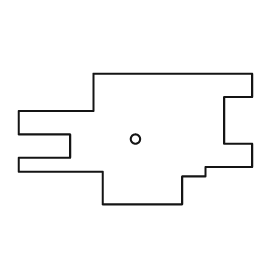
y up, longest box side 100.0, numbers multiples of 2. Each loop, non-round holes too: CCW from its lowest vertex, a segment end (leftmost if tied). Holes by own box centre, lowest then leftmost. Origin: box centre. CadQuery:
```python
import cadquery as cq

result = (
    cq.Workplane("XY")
    .moveTo(-14.0, -28.0)
    .lineTo(20.0, -28.0)
    .lineTo(20.0, -16.0)
    .lineTo(30.0, -16.0)
    .lineTo(30.0, -12.0)
    .lineTo(50.0, -12.0)
    .lineTo(50.0, -2.0)
    .lineTo(38.0, -2.0)
    .lineTo(38.0, 18.0)
    .lineTo(50.0, 18.0)
    .lineTo(50.0, 28.0)
    .lineTo(-18.0, 28.0)
    .lineTo(-18.0, 12.0)
    .lineTo(-50.0, 12.0)
    .lineTo(-50.0, 2.0)
    .lineTo(-28.0, 2.0)
    .lineTo(-28.0, -8.0)
    .lineTo(-50.0, -8.0)
    .lineTo(-50.0, -14.0)
    .lineTo(-14.0, -14.0)
    .close()
    .moveTo(0.0, 0.0)
    .circle(2.0)
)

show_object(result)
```